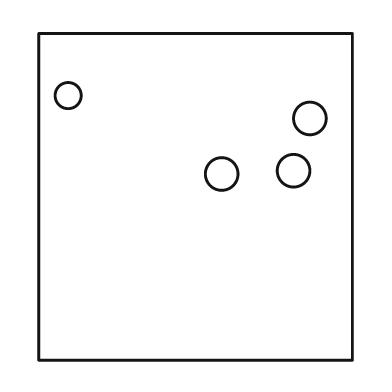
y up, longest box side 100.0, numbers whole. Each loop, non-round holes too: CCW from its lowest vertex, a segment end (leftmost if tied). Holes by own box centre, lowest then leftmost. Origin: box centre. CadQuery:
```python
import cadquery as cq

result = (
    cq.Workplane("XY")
    .moveTo(-48.0, -50.0)
    .lineTo(48.0, -50.0)
    .lineTo(48.0, 50.0)
    .lineTo(-48.0, 50.0)
    .close()
    .moveTo(8.0, 7.0)
    .circle(5.0)
    .moveTo(30.0, 8.0)
    .circle(5.0)
    .moveTo(35.0, 24.0)
    .circle(5.0)
    .moveTo(-39.0, 31.0)
    .circle(4.0)
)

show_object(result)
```